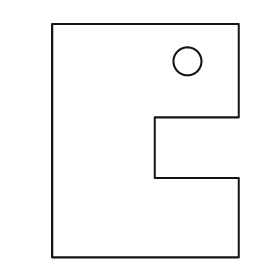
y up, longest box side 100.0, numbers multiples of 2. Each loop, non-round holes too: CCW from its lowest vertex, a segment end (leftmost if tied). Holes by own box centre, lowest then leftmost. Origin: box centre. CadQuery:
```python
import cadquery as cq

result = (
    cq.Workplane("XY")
    .moveTo(-40.0, -50.0)
    .lineTo(40.0, -50.0)
    .lineTo(40.0, -16.0)
    .lineTo(4.0, -16.0)
    .lineTo(4.0, 10.0)
    .lineTo(40.0, 10.0)
    .lineTo(40.0, 50.0)
    .lineTo(-40.0, 50.0)
    .close()
    .moveTo(18.0, 34.0)
    .circle(6.0)
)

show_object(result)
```